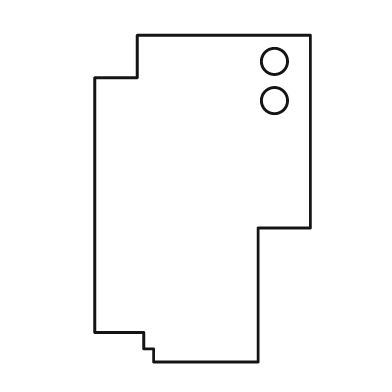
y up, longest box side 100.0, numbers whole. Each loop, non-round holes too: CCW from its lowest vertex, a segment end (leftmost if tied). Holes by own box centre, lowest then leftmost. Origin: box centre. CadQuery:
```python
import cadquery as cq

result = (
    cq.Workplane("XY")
    .moveTo(-15.0, -50.0)
    .lineTo(17.0, -50.0)
    .lineTo(17.0, -9.0)
    .lineTo(33.0, -9.0)
    .lineTo(33.0, 50.0)
    .lineTo(-20.0, 50.0)
    .lineTo(-20.0, 37.0)
    .lineTo(-33.0, 37.0)
    .lineTo(-33.0, -41.0)
    .lineTo(-18.0, -41.0)
    .lineTo(-18.0, -46.0)
    .lineTo(-15.0, -46.0)
    .close()
    .moveTo(22.0, 30.0)
    .circle(4.0)
    .moveTo(22.0, 42.0)
    .circle(4.0)
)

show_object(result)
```